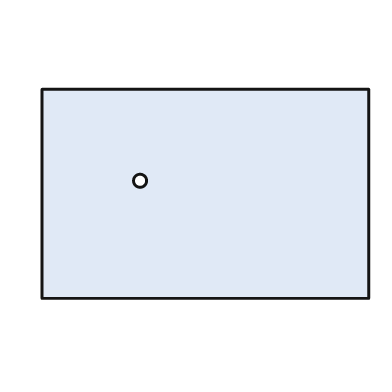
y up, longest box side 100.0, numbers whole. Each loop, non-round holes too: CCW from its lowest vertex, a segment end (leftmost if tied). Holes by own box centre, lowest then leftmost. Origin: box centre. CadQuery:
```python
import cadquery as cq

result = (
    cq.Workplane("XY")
    .moveTo(-50.0, -32.0)
    .lineTo(50.0, -32.0)
    .lineTo(50.0, 32.0)
    .lineTo(-50.0, 32.0)
    .close()
    .moveTo(-20.0, 4.0)
    .circle(2.0)
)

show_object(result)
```